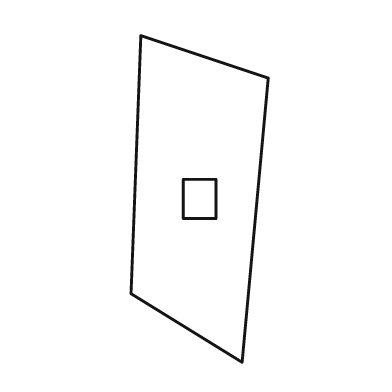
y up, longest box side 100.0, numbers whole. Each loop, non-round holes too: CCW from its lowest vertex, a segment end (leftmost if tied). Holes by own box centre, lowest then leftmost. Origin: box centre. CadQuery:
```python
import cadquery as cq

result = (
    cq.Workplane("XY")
    .moveTo(13.0, -50.0)
    .lineTo(21.0, 37.0)
    .lineTo(-18.0, 50.0)
    .lineTo(-21.0, -29.0)
    .close()
    .moveTo(-5.0, -6.0)
    .lineTo(5.0, -6.0)
    .lineTo(5.0, 6.0)
    .lineTo(-5.0, 6.0)
    .close()
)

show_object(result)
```